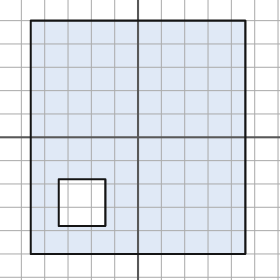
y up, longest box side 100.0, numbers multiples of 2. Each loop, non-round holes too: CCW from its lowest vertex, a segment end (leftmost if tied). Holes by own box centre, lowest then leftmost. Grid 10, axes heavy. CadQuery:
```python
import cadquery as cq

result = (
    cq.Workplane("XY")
    .moveTo(-46.0, -50.0)
    .lineTo(46.0, -50.0)
    .lineTo(46.0, 50.0)
    .lineTo(-46.0, 50.0)
    .close()
    .moveTo(-34.0, -38.0)
    .lineTo(-14.0, -38.0)
    .lineTo(-14.0, -18.0)
    .lineTo(-34.0, -18.0)
    .close()
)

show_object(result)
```